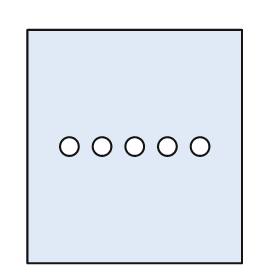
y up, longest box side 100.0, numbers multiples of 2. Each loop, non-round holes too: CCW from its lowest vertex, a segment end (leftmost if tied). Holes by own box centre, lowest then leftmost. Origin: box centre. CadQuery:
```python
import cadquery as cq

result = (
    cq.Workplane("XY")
    .moveTo(-46.0, -50.0)
    .lineTo(46.0, -50.0)
    .lineTo(46.0, 50.0)
    .lineTo(-46.0, 50.0)
    .close()
    .moveTo(-28.0, 0.0)
    .circle(4.0)
    .moveTo(-14.0, 0.0)
    .circle(4.0)
    .moveTo(0.0, 0.0)
    .circle(4.0)
    .moveTo(14.0, 0.0)
    .circle(4.0)
    .moveTo(28.0, 0.0)
    .circle(4.0)
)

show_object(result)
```